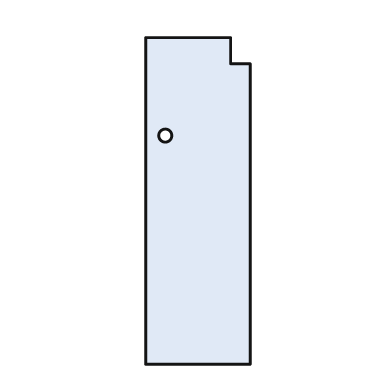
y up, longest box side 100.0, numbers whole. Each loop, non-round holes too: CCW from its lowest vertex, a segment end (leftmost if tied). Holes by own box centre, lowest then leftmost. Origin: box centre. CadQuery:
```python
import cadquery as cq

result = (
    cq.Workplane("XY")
    .moveTo(-16.0, -50.0)
    .lineTo(16.0, -50.0)
    .lineTo(16.0, 42.0)
    .lineTo(10.0, 42.0)
    .lineTo(10.0, 50.0)
    .lineTo(-16.0, 50.0)
    .close()
    .moveTo(-10.0, 20.0)
    .circle(2.0)
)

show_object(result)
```